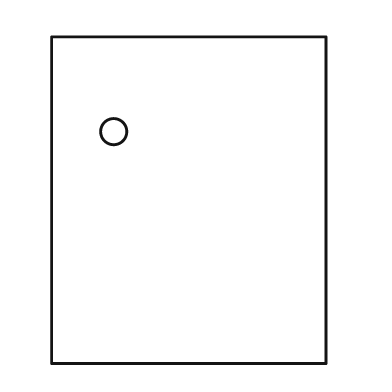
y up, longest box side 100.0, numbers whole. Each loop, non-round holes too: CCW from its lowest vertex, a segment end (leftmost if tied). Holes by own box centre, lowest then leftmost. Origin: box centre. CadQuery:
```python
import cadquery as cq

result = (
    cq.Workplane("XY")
    .moveTo(-42.0, -50.0)
    .lineTo(42.0, -50.0)
    .lineTo(42.0, 50.0)
    .lineTo(-42.0, 50.0)
    .close()
    .moveTo(-23.0, 21.0)
    .circle(4.0)
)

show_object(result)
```